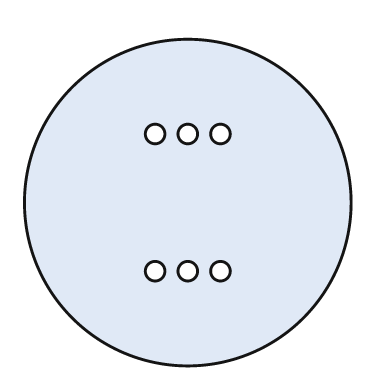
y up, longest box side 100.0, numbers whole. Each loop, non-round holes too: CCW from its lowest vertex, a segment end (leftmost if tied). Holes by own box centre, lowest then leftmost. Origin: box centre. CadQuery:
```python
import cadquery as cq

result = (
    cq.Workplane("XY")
    .moveTo(0.0, 0.0)
    .circle(50.0)
    .moveTo(-10.0, -21.0)
    .circle(3.0)
    .moveTo(0.0, -21.0)
    .circle(3.0)
    .moveTo(10.0, -21.0)
    .circle(3.0)
    .moveTo(-10.0, 21.0)
    .circle(3.0)
    .moveTo(0.0, 21.0)
    .circle(3.0)
    .moveTo(10.0, 21.0)
    .circle(3.0)
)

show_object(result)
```